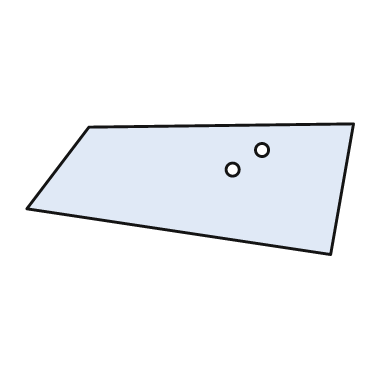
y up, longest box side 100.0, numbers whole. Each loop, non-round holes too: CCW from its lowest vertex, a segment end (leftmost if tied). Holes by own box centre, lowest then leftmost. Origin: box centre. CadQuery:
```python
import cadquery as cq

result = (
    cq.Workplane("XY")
    .moveTo(43.0, -20.0)
    .lineTo(50.0, 20.0)
    .lineTo(-31.0, 19.0)
    .lineTo(-50.0, -6.0)
    .close()
    .moveTo(13.0, 6.0)
    .circle(2.0)
    .moveTo(22.0, 12.0)
    .circle(2.0)
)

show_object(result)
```